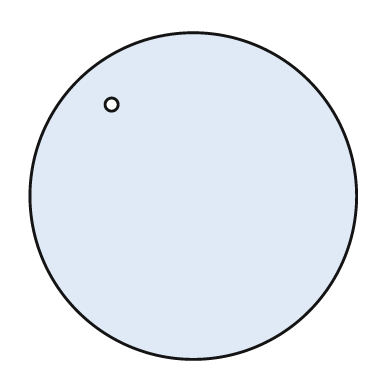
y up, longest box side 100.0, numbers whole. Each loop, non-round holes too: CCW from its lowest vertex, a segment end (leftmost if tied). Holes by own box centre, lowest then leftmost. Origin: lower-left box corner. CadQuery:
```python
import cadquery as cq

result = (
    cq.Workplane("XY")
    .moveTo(50.0, 50.0)
    .circle(50.0)
    .moveTo(25.0, 78.0)
    .circle(2.0)
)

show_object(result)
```